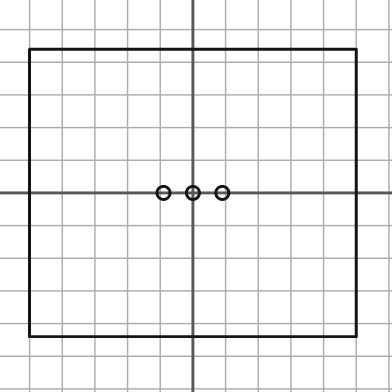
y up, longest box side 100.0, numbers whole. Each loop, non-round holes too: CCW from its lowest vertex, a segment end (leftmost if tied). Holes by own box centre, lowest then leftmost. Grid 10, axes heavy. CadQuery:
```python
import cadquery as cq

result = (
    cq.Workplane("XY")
    .moveTo(-50.0, -44.0)
    .lineTo(50.0, -44.0)
    .lineTo(50.0, 44.0)
    .lineTo(-50.0, 44.0)
    .close()
    .moveTo(-9.0, 0.0)
    .circle(2.0)
    .moveTo(0.0, 0.0)
    .circle(2.0)
    .moveTo(9.0, 0.0)
    .circle(2.0)
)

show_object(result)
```